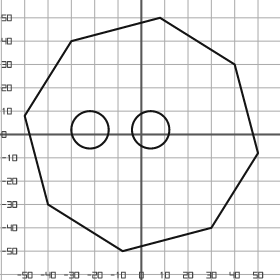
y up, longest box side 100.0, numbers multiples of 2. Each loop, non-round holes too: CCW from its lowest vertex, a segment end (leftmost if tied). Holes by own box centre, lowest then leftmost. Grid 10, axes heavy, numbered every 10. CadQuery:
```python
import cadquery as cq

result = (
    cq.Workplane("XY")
    .moveTo(-8.0, -50.0)
    .lineTo(30.0, -40.0)
    .lineTo(50.0, -8.0)
    .lineTo(40.0, 30.0)
    .lineTo(8.0, 50.0)
    .lineTo(-30.0, 40.0)
    .lineTo(-50.0, 8.0)
    .lineTo(-40.0, -30.0)
    .close()
    .moveTo(-22.0, 2.0)
    .circle(8.0)
    .moveTo(4.0, 2.0)
    .circle(8.0)
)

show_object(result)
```